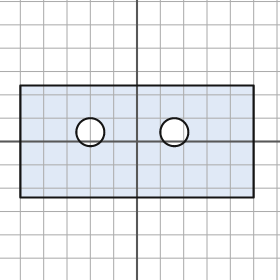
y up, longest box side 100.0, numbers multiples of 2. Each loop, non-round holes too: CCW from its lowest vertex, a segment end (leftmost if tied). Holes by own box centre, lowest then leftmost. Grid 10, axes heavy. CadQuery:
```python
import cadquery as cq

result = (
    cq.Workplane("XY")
    .moveTo(-50.0, -24.0)
    .lineTo(50.0, -24.0)
    .lineTo(50.0, 24.0)
    .lineTo(-50.0, 24.0)
    .close()
    .moveTo(-20.0, 4.0)
    .circle(6.0)
    .moveTo(16.0, 4.0)
    .circle(6.0)
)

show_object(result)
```